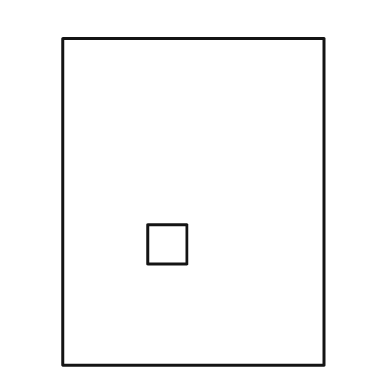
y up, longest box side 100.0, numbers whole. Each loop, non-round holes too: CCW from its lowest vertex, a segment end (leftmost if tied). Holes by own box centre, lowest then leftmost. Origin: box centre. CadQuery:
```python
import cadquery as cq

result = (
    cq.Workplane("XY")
    .moveTo(-40.0, -50.0)
    .lineTo(40.0, -50.0)
    .lineTo(40.0, 50.0)
    .lineTo(-40.0, 50.0)
    .close()
    .moveTo(-14.0, -19.0)
    .lineTo(-2.0, -19.0)
    .lineTo(-2.0, -7.0)
    .lineTo(-14.0, -7.0)
    .close()
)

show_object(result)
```